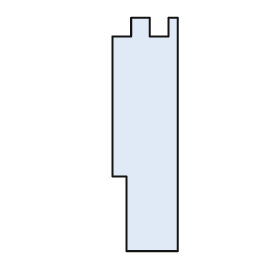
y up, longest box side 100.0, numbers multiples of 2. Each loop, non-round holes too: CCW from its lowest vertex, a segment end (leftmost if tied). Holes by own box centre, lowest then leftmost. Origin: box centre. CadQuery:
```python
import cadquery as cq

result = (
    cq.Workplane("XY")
    .moveTo(-8.0, -50.0)
    .lineTo(14.0, -50.0)
    .lineTo(14.0, 50.0)
    .lineTo(10.0, 50.0)
    .lineTo(10.0, 42.0)
    .lineTo(2.0, 42.0)
    .lineTo(2.0, 50.0)
    .lineTo(-6.0, 50.0)
    .lineTo(-6.0, 42.0)
    .lineTo(-14.0, 42.0)
    .lineTo(-14.0, -18.0)
    .lineTo(-8.0, -18.0)
    .close()
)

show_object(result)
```